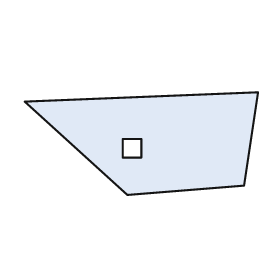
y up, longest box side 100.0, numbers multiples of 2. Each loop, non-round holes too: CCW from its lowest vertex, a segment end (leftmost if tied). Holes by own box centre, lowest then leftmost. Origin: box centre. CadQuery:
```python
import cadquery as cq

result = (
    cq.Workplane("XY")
    .moveTo(-6.0, -22.0)
    .lineTo(44.0, -18.0)
    .lineTo(50.0, 22.0)
    .lineTo(-50.0, 18.0)
    .close()
    .moveTo(-8.0, -6.0)
    .lineTo(0.0, -6.0)
    .lineTo(0.0, 2.0)
    .lineTo(-8.0, 2.0)
    .close()
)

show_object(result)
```